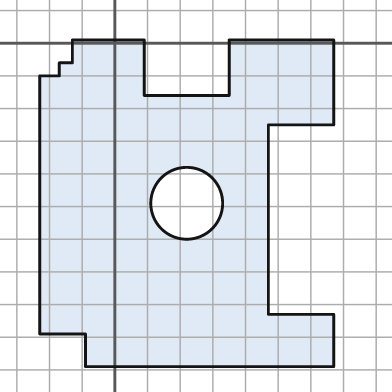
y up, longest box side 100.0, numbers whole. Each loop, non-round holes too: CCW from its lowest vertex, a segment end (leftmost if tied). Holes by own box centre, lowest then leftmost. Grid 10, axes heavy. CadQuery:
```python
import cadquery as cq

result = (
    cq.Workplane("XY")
    .moveTo(-9.0, -99.0)
    .lineTo(67.0, -99.0)
    .lineTo(67.0, -83.0)
    .lineTo(47.0, -83.0)
    .lineTo(47.0, -25.0)
    .lineTo(67.0, -25.0)
    .lineTo(67.0, 1.0)
    .lineTo(35.0, 1.0)
    .lineTo(35.0, -16.0)
    .lineTo(9.0, -16.0)
    .lineTo(9.0, 1.0)
    .lineTo(-13.0, 1.0)
    .lineTo(-13.0, -6.0)
    .lineTo(-17.0, -6.0)
    .lineTo(-17.0, -10.0)
    .lineTo(-23.0, -10.0)
    .lineTo(-23.0, -89.0)
    .lineTo(-9.0, -89.0)
    .close()
    .moveTo(22.0, -49.0)
    .circle(11.0)
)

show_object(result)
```